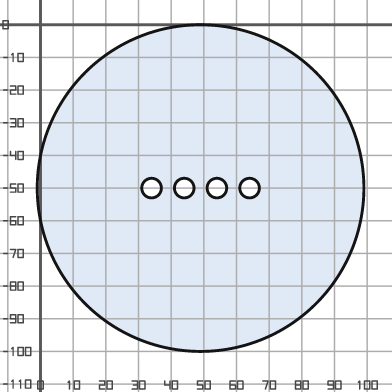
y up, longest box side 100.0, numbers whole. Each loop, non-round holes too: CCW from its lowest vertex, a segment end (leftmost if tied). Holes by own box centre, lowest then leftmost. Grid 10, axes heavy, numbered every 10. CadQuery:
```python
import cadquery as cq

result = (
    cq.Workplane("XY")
    .moveTo(49.0, -50.0)
    .circle(50.0)
    .moveTo(34.0, -50.0)
    .circle(3.0)
    .moveTo(44.0, -50.0)
    .circle(3.0)
    .moveTo(54.0, -50.0)
    .circle(3.0)
    .moveTo(64.0, -50.0)
    .circle(3.0)
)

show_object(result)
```